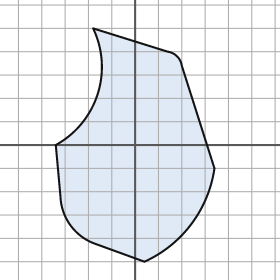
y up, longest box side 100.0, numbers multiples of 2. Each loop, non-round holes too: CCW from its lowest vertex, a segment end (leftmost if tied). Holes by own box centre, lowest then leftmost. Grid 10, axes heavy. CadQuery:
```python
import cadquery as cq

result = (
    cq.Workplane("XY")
    .moveTo(4.0, -50.0)
    .threePointArc((24.0, -34.0), (34.0, -10.0))
    .lineTo(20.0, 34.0)
    .threePointArc((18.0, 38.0), (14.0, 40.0))
    .lineTo(-18.0, 50.0)
    .threePointArc((-16.0, 22.0), (-34.0, 0.0))
    .lineTo(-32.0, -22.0)
    .threePointArc((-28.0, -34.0), (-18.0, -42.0))
    .close()
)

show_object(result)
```